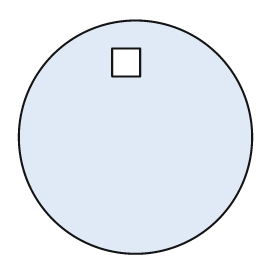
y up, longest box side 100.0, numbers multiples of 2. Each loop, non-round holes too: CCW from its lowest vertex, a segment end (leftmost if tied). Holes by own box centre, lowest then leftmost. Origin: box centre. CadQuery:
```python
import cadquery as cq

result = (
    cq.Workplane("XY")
    .moveTo(0.0, 0.0)
    .circle(50.0)
    .moveTo(-10.0, 26.0)
    .lineTo(2.0, 26.0)
    .lineTo(2.0, 38.0)
    .lineTo(-10.0, 38.0)
    .close()
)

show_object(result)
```